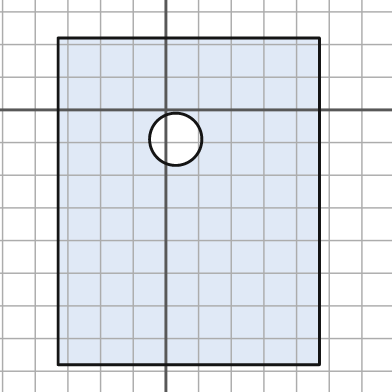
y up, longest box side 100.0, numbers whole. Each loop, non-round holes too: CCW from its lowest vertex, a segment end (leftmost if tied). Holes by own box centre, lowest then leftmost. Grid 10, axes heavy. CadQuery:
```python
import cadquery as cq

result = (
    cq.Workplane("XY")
    .moveTo(-33.0, -78.0)
    .lineTo(47.0, -78.0)
    .lineTo(47.0, 22.0)
    .lineTo(-33.0, 22.0)
    .close()
    .moveTo(3.0, -9.0)
    .circle(8.0)
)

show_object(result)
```